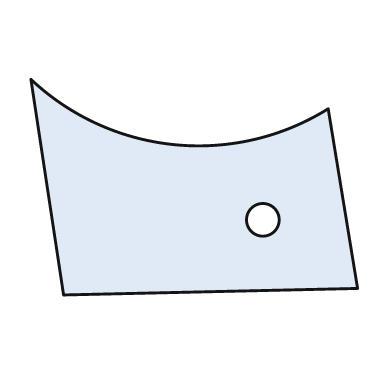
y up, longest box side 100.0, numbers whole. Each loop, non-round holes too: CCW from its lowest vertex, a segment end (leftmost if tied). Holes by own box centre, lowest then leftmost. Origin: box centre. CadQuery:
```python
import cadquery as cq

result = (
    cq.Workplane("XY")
    .moveTo(-40.0, -33.0)
    .lineTo(50.0, -31.0)
    .lineTo(41.0, 24.0)
    .threePointArc((-6.0, 13.0), (-50.0, 33.0))
    .close()
    .moveTo(21.0, -10.0)
    .circle(5.0)
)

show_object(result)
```